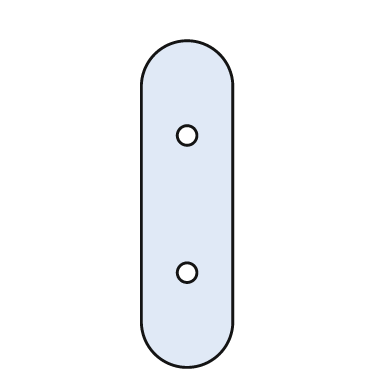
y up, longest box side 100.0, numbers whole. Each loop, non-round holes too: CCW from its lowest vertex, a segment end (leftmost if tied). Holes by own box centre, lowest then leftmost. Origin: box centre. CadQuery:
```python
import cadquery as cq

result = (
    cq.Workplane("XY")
    .moveTo(-14.0, -36.0)
    .threePointArc((0.0, -50.0), (14.0, -36.0))
    .lineTo(14.0, 36.0)
    .threePointArc((0.0, 50.0), (-14.0, 36.0))
    .close()
    .moveTo(0.0, -21.0)
    .circle(3.0)
    .moveTo(0.0, 21.0)
    .circle(3.0)
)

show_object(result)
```